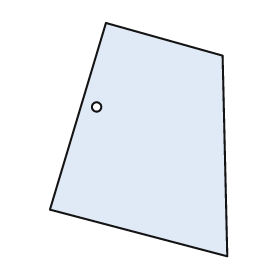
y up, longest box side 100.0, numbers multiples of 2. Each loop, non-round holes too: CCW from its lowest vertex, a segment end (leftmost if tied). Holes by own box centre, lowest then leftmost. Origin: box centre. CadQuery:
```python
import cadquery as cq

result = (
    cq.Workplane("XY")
    .moveTo(38.0, -50.0)
    .lineTo(36.0, 36.0)
    .lineTo(-14.0, 50.0)
    .lineTo(-38.0, -30.0)
    .close()
    .moveTo(-18.0, 14.0)
    .circle(2.0)
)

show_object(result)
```